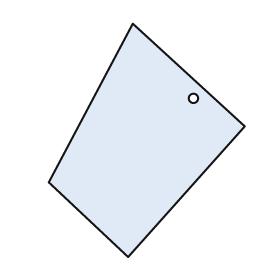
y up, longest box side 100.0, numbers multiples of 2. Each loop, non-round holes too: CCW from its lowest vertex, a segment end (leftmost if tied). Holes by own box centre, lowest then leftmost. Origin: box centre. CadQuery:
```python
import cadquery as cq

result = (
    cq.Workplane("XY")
    .moveTo(-8.0, -50.0)
    .lineTo(42.0, 6.0)
    .lineTo(-6.0, 50.0)
    .lineTo(-42.0, -18.0)
    .close()
    .moveTo(20.0, 18.0)
    .circle(2.0)
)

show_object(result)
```